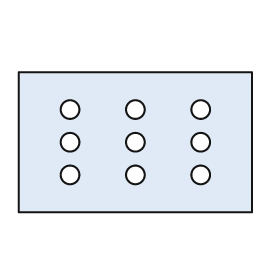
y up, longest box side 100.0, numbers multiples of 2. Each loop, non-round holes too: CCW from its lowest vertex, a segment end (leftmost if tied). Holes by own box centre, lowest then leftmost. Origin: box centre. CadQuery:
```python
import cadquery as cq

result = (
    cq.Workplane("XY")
    .moveTo(-50.0, -30.0)
    .lineTo(50.0, -30.0)
    .lineTo(50.0, 30.0)
    .lineTo(-50.0, 30.0)
    .close()
    .moveTo(-28.0, -14.0)
    .circle(4.0)
    .moveTo(0.0, -14.0)
    .circle(4.0)
    .moveTo(28.0, -14.0)
    .circle(4.0)
    .moveTo(-28.0, 0.0)
    .circle(4.0)
    .moveTo(0.0, 0.0)
    .circle(4.0)
    .moveTo(28.0, 0.0)
    .circle(4.0)
    .moveTo(-28.0, 14.0)
    .circle(4.0)
    .moveTo(0.0, 14.0)
    .circle(4.0)
    .moveTo(28.0, 14.0)
    .circle(4.0)
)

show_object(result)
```